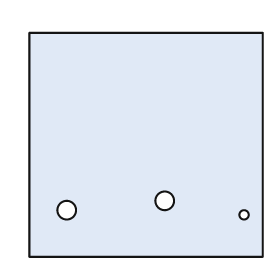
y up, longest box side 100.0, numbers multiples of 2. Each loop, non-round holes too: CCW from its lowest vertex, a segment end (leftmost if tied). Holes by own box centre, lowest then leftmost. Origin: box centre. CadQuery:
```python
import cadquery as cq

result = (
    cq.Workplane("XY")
    .moveTo(-50.0, -48.0)
    .lineTo(50.0, -48.0)
    .lineTo(50.0, 48.0)
    .lineTo(-50.0, 48.0)
    .close()
    .moveTo(42.0, -30.0)
    .circle(2.0)
    .moveTo(-34.0, -28.0)
    .circle(4.0)
    .moveTo(8.0, -24.0)
    .circle(4.0)
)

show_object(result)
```